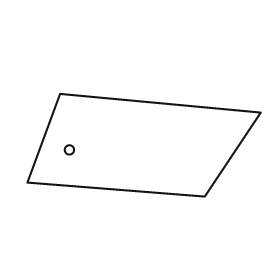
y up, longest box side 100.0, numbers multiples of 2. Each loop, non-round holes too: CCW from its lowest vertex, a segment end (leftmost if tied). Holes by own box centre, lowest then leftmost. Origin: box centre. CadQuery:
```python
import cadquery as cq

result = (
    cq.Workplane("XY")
    .moveTo(26.0, -22.0)
    .lineTo(50.0, 14.0)
    .lineTo(-36.0, 22.0)
    .lineTo(-50.0, -16.0)
    .close()
    .moveTo(-32.0, -2.0)
    .circle(2.0)
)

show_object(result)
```